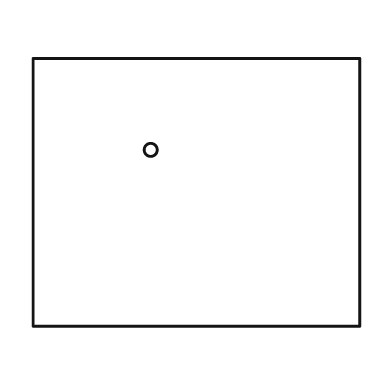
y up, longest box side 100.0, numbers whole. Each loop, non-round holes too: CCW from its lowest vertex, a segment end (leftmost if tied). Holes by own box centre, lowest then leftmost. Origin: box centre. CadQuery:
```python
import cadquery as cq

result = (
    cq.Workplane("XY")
    .moveTo(-50.0, -41.0)
    .lineTo(50.0, -41.0)
    .lineTo(50.0, 41.0)
    .lineTo(-50.0, 41.0)
    .close()
    .moveTo(-14.0, 13.0)
    .circle(2.0)
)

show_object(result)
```